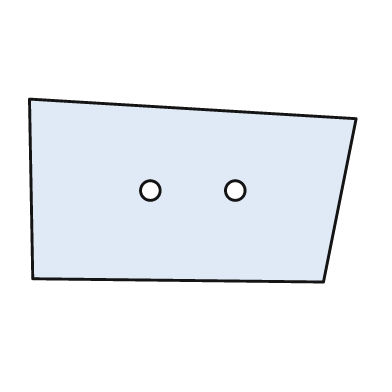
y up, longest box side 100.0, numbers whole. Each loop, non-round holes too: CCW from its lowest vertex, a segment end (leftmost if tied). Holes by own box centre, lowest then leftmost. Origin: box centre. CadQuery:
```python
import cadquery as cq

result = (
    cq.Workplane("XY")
    .moveTo(40.0, -28.0)
    .lineTo(50.0, 22.0)
    .lineTo(-50.0, 28.0)
    .lineTo(-49.0, -27.0)
    .close()
    .moveTo(-13.0, 0.0)
    .circle(3.0)
    .moveTo(13.0, 0.0)
    .circle(3.0)
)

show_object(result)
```